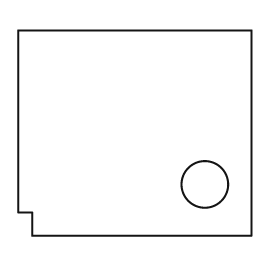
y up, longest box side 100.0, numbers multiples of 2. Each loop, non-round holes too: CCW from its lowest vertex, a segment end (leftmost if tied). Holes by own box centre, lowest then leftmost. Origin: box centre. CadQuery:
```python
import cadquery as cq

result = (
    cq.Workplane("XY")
    .moveTo(-44.0, -44.0)
    .lineTo(50.0, -44.0)
    .lineTo(50.0, 44.0)
    .lineTo(-50.0, 44.0)
    .lineTo(-50.0, -34.0)
    .lineTo(-44.0, -34.0)
    .close()
    .moveTo(30.0, -22.0)
    .circle(10.0)
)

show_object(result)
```